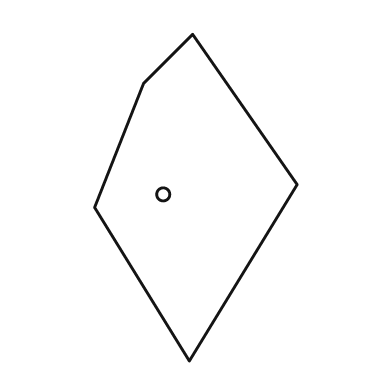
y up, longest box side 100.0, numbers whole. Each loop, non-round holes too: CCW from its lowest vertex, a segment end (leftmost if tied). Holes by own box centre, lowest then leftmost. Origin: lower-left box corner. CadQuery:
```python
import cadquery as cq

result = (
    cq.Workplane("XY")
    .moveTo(29.0, 0.0)
    .lineTo(62.0, 54.0)
    .lineTo(30.0, 100.0)
    .lineTo(15.0, 85.0)
    .lineTo(0.0, 47.0)
    .close()
    .moveTo(21.0, 51.0)
    .circle(2.0)
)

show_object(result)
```